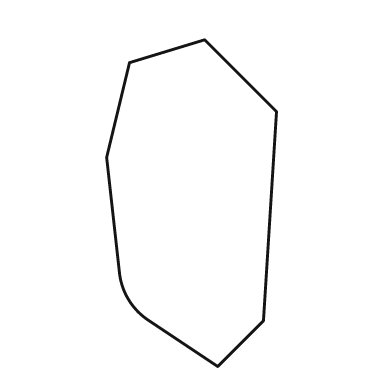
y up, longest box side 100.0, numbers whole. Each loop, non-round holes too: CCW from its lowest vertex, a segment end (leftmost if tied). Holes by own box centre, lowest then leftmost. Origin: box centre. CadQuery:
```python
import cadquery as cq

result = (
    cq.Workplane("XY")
    .moveTo(8.0, -50.0)
    .lineTo(22.0, -36.0)
    .lineTo(26.0, 28.0)
    .lineTo(4.0, 50.0)
    .lineTo(-19.0, 43.0)
    .lineTo(-26.0, 14.0)
    .lineTo(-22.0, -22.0)
    .threePointArc((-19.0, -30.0), (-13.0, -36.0))
    .close()
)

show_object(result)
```